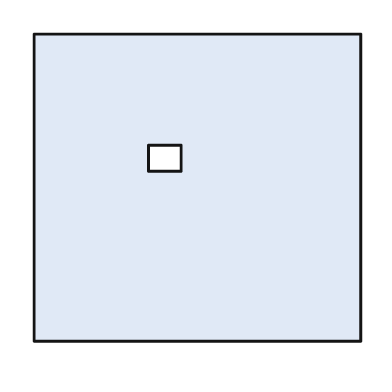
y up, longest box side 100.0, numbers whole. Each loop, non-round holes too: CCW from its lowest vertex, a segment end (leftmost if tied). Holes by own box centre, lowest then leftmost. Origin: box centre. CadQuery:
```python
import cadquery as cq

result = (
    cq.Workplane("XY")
    .moveTo(-50.0, -47.0)
    .lineTo(50.0, -47.0)
    .lineTo(50.0, 47.0)
    .lineTo(-50.0, 47.0)
    .close()
    .moveTo(-15.0, 5.0)
    .lineTo(-5.0, 5.0)
    .lineTo(-5.0, 13.0)
    .lineTo(-15.0, 13.0)
    .close()
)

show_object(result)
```